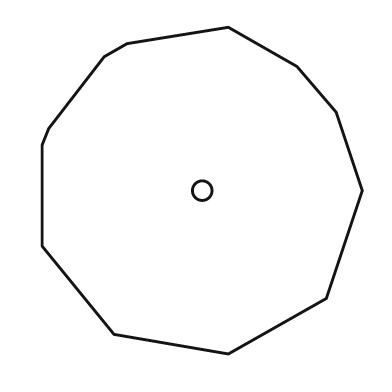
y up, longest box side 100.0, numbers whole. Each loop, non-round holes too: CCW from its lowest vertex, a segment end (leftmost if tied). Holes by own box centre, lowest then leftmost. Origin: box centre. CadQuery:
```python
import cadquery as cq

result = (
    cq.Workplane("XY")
    .moveTo(8.0, -50.0)
    .lineTo(38.0, -33.0)
    .lineTo(49.0, 0.0)
    .lineTo(41.0, 24.0)
    .lineTo(29.0, 38.0)
    .lineTo(8.0, 50.0)
    .lineTo(-23.0, 45.0)
    .lineTo(-30.0, 41.0)
    .lineTo(-47.0, 19.0)
    .lineTo(-49.0, 14.0)
    .lineTo(-49.0, -17.0)
    .lineTo(-27.0, -44.0)
    .close()
    .moveTo(0.0, 0.0)
    .circle(3.0)
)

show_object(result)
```